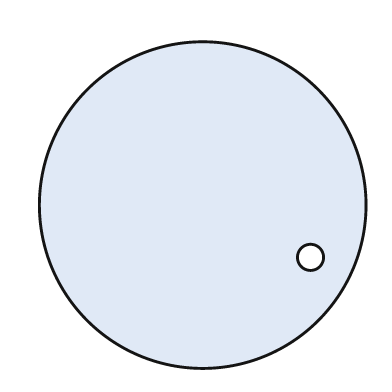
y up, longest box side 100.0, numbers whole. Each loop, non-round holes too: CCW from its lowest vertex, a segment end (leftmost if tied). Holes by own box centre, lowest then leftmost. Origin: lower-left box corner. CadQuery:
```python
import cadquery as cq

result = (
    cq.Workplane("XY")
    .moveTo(50.0, 50.0)
    .circle(50.0)
    .moveTo(83.0, 34.0)
    .circle(4.0)
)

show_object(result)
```